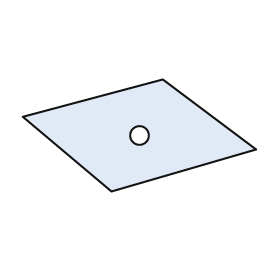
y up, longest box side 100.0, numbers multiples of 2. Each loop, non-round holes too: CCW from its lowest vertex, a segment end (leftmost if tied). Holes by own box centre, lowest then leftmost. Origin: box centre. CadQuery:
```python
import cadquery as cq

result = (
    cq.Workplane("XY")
    .moveTo(-12.0, -24.0)
    .lineTo(50.0, -6.0)
    .lineTo(10.0, 24.0)
    .lineTo(-50.0, 8.0)
    .close()
    .moveTo(0.0, 0.0)
    .circle(4.0)
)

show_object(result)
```